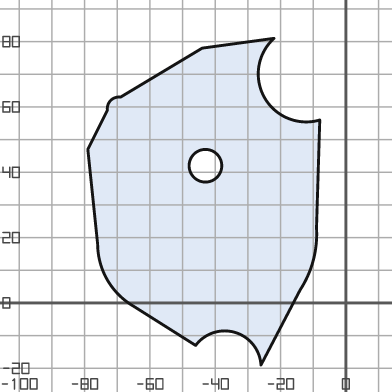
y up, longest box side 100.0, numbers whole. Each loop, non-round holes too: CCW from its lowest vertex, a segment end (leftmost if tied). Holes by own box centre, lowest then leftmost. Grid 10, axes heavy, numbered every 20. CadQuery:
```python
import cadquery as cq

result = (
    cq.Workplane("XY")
    .moveTo(-26.0, -19.0)
    .lineTo(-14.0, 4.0)
    .threePointArc((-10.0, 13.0), (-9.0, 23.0))
    .lineTo(-8.0, 56.0)
    .threePointArc((-25.0, 63.0), (-22.0, 81.0))
    .lineTo(-44.0, 78.0)
    .lineTo(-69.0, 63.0)
    .threePointArc((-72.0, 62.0), (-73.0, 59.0))
    .lineTo(-79.0, 47.0)
    .lineTo(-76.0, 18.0)
    .threePointArc((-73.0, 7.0), (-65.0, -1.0))
    .lineTo(-46.0, -13.0)
    .threePointArc((-34.0, -9.0), (-26.0, -19.0))
    .close()
    .moveTo(-43.0, 42.0)
    .circle(5.0)
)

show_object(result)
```